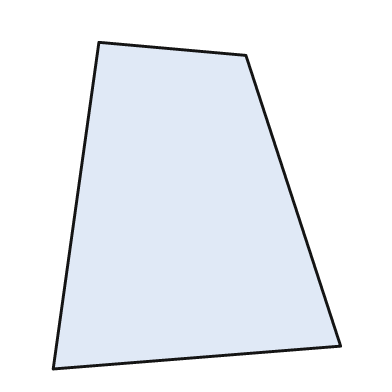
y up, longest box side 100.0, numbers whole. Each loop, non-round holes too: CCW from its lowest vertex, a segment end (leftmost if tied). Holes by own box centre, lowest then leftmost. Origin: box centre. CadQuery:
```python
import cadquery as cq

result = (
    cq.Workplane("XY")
    .moveTo(-44.0, -50.0)
    .lineTo(44.0, -43.0)
    .lineTo(15.0, 46.0)
    .lineTo(-30.0, 50.0)
    .close()
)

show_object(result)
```